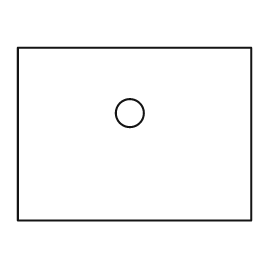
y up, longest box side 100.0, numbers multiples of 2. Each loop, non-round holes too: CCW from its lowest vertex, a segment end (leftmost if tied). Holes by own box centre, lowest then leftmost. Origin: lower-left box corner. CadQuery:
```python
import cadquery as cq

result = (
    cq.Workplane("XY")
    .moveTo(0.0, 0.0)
    .lineTo(100.0, 0.0)
    .lineTo(100.0, 74.0)
    .lineTo(0.0, 74.0)
    .close()
    .moveTo(48.0, 46.0)
    .circle(6.0)
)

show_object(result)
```